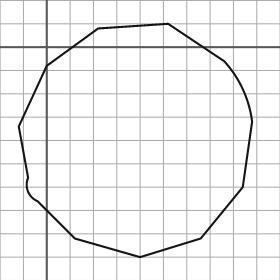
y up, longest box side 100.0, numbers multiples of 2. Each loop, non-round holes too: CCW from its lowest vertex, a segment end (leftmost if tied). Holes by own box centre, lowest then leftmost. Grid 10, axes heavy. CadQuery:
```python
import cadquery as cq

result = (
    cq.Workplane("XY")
    .moveTo(40.0, -90.0)
    .lineTo(66.0, -82.0)
    .lineTo(84.0, -60.0)
    .lineTo(88.0, -32.0)
    .threePointArc((84.0, -18.0), (76.0, -6.0))
    .lineTo(52.0, 10.0)
    .lineTo(22.0, 8.0)
    .lineTo(0.0, -8.0)
    .lineTo(-12.0, -34.0)
    .lineTo(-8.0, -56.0)
    .threePointArc((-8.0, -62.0), (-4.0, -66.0))
    .lineTo(12.0, -82.0)
    .close()
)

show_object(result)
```